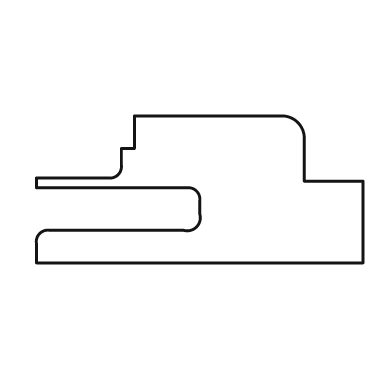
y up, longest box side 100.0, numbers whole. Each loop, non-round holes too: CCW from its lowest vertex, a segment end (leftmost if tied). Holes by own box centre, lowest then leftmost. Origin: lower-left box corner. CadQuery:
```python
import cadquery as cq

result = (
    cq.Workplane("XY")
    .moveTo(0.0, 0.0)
    .lineTo(100.0, 0.0)
    .lineTo(100.0, 25.0)
    .lineTo(82.0, 25.0)
    .lineTo(82.0, 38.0)
    .threePointArc((80.0, 43.0), (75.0, 45.0))
    .lineTo(30.0, 45.0)
    .lineTo(30.0, 35.0)
    .lineTo(26.0, 35.0)
    .lineTo(26.0, 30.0)
    .threePointArc((25.0, 27.0), (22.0, 26.0))
    .lineTo(0.0, 26.0)
    .lineTo(0.0, 23.0)
    .lineTo(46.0, 23.0)
    .threePointArc((49.0, 22.0), (50.0, 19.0))
    .lineTo(50.0, 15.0)
    .threePointArc((49.0, 11.0), (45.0, 10.0))
    .lineTo(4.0, 10.0)
    .threePointArc((1.0, 9.0), (0.0, 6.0))
    .close()
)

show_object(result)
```